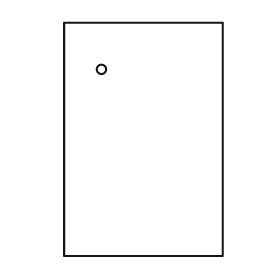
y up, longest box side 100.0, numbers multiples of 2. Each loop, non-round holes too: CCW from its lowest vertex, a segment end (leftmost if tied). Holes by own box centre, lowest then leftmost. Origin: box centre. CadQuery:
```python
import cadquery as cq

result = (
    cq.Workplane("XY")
    .moveTo(-34.0, -50.0)
    .lineTo(34.0, -50.0)
    .lineTo(34.0, 50.0)
    .lineTo(-34.0, 50.0)
    .close()
    .moveTo(-18.0, 30.0)
    .circle(2.0)
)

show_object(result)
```